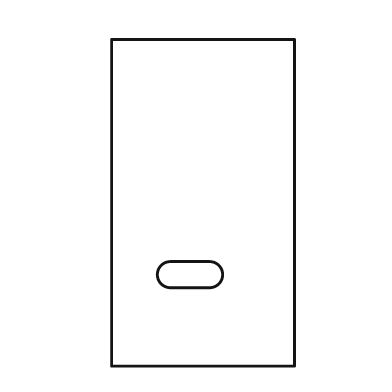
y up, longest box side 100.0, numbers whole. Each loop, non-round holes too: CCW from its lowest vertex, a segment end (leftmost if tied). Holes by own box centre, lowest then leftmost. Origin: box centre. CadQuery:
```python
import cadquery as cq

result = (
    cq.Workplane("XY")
    .moveTo(-28.0, -50.0)
    .lineTo(28.0, -50.0)
    .lineTo(28.0, 50.0)
    .lineTo(-28.0, 50.0)
    .close()
    .moveTo(-10.0, -26.0)
    .lineTo(2.0, -26.0)
    .threePointArc((6.0, -22.0), (2.0, -18.0))
    .lineTo(-10.0, -18.0)
    .threePointArc((-14.0, -22.0), (-10.0, -26.0))
    .close()
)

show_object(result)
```